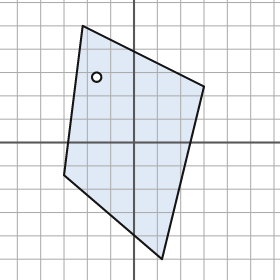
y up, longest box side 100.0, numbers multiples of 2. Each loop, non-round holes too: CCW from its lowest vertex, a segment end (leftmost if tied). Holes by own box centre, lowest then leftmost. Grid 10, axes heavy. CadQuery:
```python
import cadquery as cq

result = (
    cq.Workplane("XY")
    .moveTo(12.0, -50.0)
    .lineTo(30.0, 24.0)
    .lineTo(-22.0, 50.0)
    .lineTo(-30.0, -14.0)
    .close()
    .moveTo(-16.0, 28.0)
    .circle(2.0)
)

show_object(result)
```